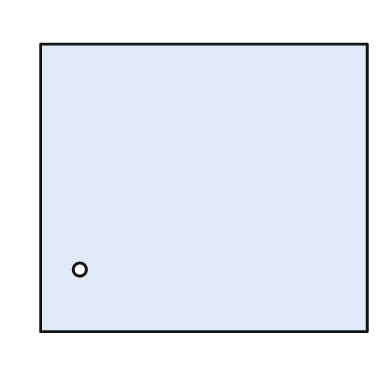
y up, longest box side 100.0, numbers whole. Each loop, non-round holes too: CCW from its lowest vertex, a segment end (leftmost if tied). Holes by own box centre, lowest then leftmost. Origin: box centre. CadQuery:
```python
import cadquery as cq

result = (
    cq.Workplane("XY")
    .moveTo(-50.0, -44.0)
    .lineTo(50.0, -44.0)
    .lineTo(50.0, 44.0)
    .lineTo(-50.0, 44.0)
    .close()
    .moveTo(-38.0, -25.0)
    .circle(2.0)
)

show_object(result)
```